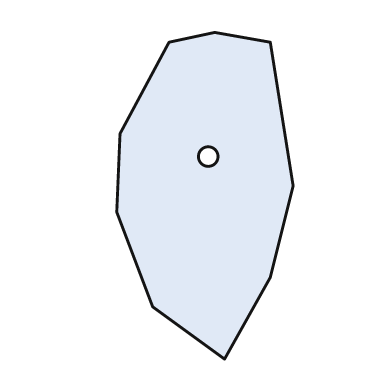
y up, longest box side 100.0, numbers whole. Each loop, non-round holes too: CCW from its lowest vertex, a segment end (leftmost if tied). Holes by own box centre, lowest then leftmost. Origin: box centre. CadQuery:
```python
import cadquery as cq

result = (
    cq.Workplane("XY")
    .moveTo(6.0, -50.0)
    .lineTo(20.0, -25.0)
    .lineTo(27.0, 3.0)
    .lineTo(20.0, 47.0)
    .lineTo(3.0, 50.0)
    .lineTo(-11.0, 47.0)
    .lineTo(-26.0, 19.0)
    .lineTo(-27.0, -5.0)
    .lineTo(-16.0, -34.0)
    .close()
    .moveTo(1.0, 12.0)
    .circle(3.0)
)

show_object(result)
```